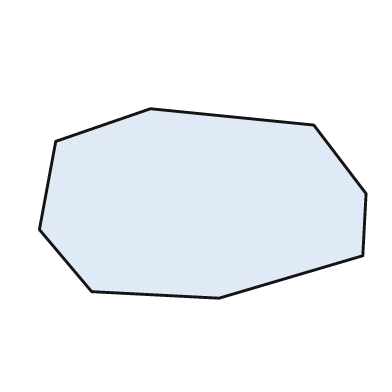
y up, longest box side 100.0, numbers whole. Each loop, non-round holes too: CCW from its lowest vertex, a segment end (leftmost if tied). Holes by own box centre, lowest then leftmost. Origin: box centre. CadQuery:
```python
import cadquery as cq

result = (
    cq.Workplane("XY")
    .moveTo(5.0, -29.0)
    .lineTo(49.0, -16.0)
    .lineTo(50.0, 3.0)
    .lineTo(34.0, 24.0)
    .lineTo(-16.0, 29.0)
    .lineTo(-45.0, 19.0)
    .lineTo(-50.0, -8.0)
    .lineTo(-34.0, -27.0)
    .close()
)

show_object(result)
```